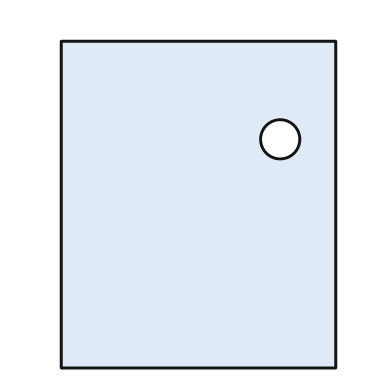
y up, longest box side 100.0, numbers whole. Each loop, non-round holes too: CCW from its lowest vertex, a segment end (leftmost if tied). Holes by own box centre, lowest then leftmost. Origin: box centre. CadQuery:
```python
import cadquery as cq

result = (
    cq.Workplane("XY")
    .moveTo(-42.0, -50.0)
    .lineTo(42.0, -50.0)
    .lineTo(42.0, 50.0)
    .lineTo(-42.0, 50.0)
    .close()
    .moveTo(25.0, 20.0)
    .circle(6.0)
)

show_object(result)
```